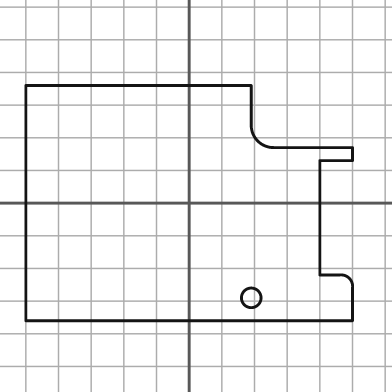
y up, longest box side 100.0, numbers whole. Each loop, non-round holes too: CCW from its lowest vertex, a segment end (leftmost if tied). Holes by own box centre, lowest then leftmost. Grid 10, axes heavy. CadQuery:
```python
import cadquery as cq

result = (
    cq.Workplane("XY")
    .moveTo(-50.0, -36.0)
    .lineTo(50.0, -36.0)
    .lineTo(50.0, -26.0)
    .threePointArc((49.0, -23.0), (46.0, -22.0))
    .lineTo(40.0, -22.0)
    .lineTo(40.0, 13.0)
    .lineTo(50.0, 13.0)
    .lineTo(50.0, 17.0)
    .lineTo(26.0, 17.0)
    .threePointArc((21.0, 19.0), (19.0, 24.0))
    .lineTo(19.0, 36.0)
    .lineTo(-50.0, 36.0)
    .close()
    .moveTo(19.0, -29.0)
    .circle(3.0)
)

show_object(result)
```